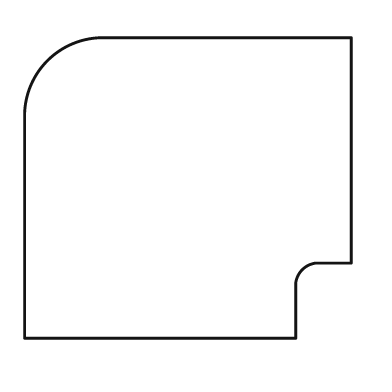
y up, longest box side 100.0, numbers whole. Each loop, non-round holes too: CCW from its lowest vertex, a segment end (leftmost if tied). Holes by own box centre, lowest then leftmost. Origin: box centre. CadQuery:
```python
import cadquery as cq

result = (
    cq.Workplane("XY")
    .moveTo(-50.0, -46.0)
    .lineTo(33.0, -46.0)
    .lineTo(33.0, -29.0)
    .threePointArc((35.0, -25.0), (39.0, -23.0))
    .lineTo(50.0, -23.0)
    .lineTo(50.0, 46.0)
    .lineTo(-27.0, 46.0)
    .threePointArc((-43.0, 39.0), (-50.0, 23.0))
    .close()
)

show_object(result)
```